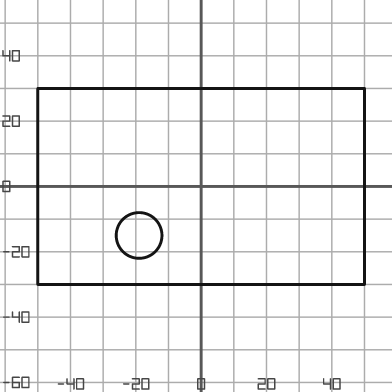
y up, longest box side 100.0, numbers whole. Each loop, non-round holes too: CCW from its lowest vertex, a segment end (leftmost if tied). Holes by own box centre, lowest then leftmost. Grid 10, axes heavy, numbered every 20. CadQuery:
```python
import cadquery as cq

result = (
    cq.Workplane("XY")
    .moveTo(-50.0, -30.0)
    .lineTo(50.0, -30.0)
    .lineTo(50.0, 30.0)
    .lineTo(-50.0, 30.0)
    .close()
    .moveTo(-19.0, -15.0)
    .circle(7.0)
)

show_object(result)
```